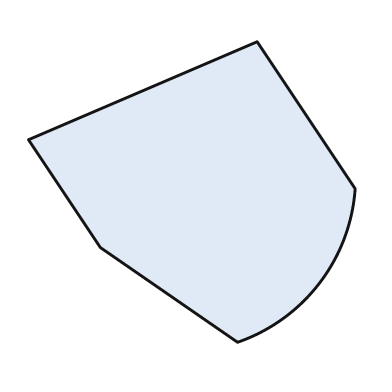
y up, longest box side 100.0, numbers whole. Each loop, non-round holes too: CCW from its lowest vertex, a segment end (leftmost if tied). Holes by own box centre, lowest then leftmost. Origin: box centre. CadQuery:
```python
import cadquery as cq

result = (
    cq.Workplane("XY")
    .moveTo(14.0, -46.0)
    .threePointArc((39.0, -28.0), (50.0, 1.0))
    .lineTo(20.0, 46.0)
    .lineTo(-50.0, 16.0)
    .lineTo(-28.0, -17.0)
    .close()
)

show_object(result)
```